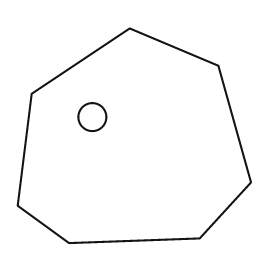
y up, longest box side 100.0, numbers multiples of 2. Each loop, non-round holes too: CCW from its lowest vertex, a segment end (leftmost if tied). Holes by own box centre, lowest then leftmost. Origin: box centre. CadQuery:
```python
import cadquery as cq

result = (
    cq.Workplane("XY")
    .moveTo(-28.0, -46.0)
    .lineTo(28.0, -44.0)
    .lineTo(50.0, -20.0)
    .lineTo(36.0, 30.0)
    .lineTo(-2.0, 46.0)
    .lineTo(-44.0, 18.0)
    .lineTo(-50.0, -30.0)
    .close()
    .moveTo(-18.0, 8.0)
    .circle(6.0)
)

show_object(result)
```